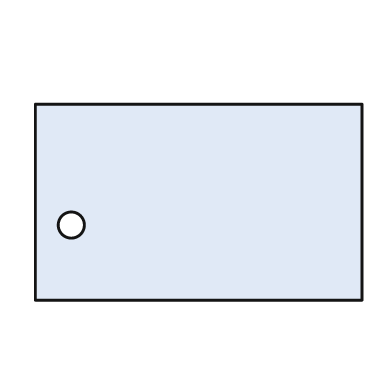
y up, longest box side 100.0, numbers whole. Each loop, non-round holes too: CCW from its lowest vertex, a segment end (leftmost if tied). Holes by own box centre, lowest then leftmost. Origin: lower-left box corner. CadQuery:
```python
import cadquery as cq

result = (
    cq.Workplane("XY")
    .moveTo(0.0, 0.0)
    .lineTo(100.0, 0.0)
    .lineTo(100.0, 60.0)
    .lineTo(0.0, 60.0)
    .close()
    .moveTo(11.0, 23.0)
    .circle(4.0)
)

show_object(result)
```